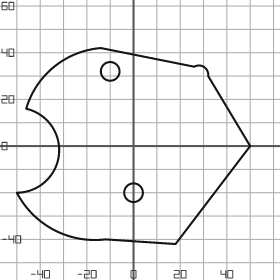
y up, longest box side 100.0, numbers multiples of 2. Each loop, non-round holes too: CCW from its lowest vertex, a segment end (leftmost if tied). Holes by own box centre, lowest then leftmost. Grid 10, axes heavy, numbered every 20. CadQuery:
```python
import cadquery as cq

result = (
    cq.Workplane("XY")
    .moveTo(18.0, -42.0)
    .lineTo(50.0, 0.0)
    .lineTo(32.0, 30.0)
    .threePointArc((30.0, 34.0), (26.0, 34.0))
    .lineTo(-14.0, 42.0)
    .threePointArc((-34.0, 34.0), (-46.0, 16.0))
    .threePointArc((-32.0, -4.0), (-50.0, -20.0))
    .threePointArc((-34.0, -36.0), (-12.0, -40.0))
    .close()
    .moveTo(0.0, -20.0)
    .circle(4.0)
    .moveTo(-10.0, 32.0)
    .circle(4.0)
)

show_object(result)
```